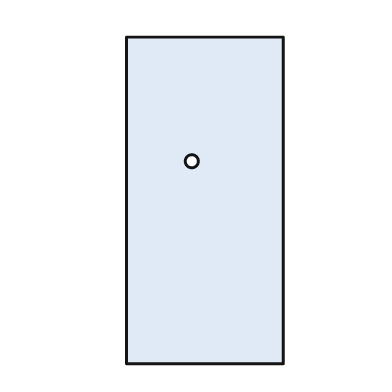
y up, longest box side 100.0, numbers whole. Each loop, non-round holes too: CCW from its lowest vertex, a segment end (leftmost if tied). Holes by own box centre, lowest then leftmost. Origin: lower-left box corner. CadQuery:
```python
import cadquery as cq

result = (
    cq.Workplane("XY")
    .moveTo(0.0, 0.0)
    .lineTo(48.0, 0.0)
    .lineTo(48.0, 100.0)
    .lineTo(0.0, 100.0)
    .close()
    .moveTo(20.0, 62.0)
    .circle(2.0)
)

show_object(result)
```